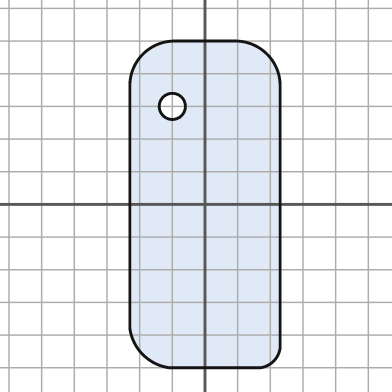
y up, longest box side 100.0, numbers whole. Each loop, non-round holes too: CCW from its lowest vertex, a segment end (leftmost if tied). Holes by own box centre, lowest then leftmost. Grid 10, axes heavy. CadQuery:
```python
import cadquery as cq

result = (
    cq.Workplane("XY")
    .moveTo(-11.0, -50.0)
    .lineTo(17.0, -50.0)
    .threePointArc((21.0, -48.0), (23.0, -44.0))
    .lineTo(23.0, 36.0)
    .threePointArc((19.0, 46.0), (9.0, 50.0))
    .lineTo(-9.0, 50.0)
    .threePointArc((-19.0, 46.0), (-23.0, 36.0))
    .lineTo(-23.0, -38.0)
    .threePointArc((-19.0, -46.0), (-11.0, -50.0))
    .close()
    .moveTo(-10.0, 30.0)
    .circle(4.0)
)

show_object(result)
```